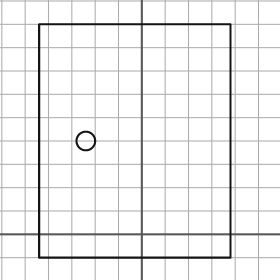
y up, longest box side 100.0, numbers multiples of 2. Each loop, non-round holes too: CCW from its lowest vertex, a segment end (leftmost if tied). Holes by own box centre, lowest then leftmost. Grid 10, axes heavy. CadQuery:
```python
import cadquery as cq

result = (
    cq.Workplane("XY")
    .moveTo(-44.0, -10.0)
    .lineTo(38.0, -10.0)
    .lineTo(38.0, 90.0)
    .lineTo(-44.0, 90.0)
    .close()
    .moveTo(-24.0, 40.0)
    .circle(4.0)
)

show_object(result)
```